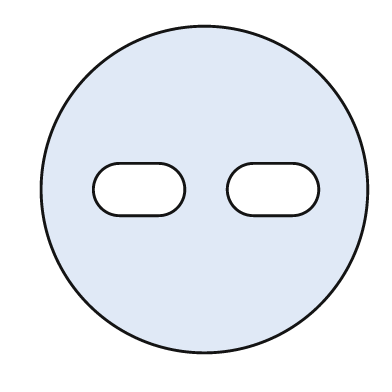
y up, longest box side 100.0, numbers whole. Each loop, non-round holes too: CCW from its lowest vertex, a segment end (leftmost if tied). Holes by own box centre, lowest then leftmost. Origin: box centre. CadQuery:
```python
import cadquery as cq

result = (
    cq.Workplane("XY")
    .moveTo(0.0, 0.0)
    .circle(50.0)
    .moveTo(-26.0, -8.0)
    .lineTo(-14.0, -8.0)
    .threePointArc((-6.0, 0.0), (-14.0, 8.0))
    .lineTo(-26.0, 8.0)
    .threePointArc((-34.0, 0.0), (-26.0, -8.0))
    .close()
    .moveTo(15.0, -8.0)
    .lineTo(27.0, -8.0)
    .threePointArc((35.0, 0.0), (27.0, 8.0))
    .lineTo(15.0, 8.0)
    .threePointArc((7.0, 0.0), (15.0, -8.0))
    .close()
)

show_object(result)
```